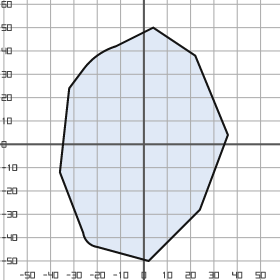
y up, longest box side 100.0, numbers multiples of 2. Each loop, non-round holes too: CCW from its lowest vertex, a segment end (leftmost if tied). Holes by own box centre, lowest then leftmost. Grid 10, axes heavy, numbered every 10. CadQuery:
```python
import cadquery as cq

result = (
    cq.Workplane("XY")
    .moveTo(2.0, -50.0)
    .lineTo(24.0, -28.0)
    .lineTo(36.0, 4.0)
    .lineTo(22.0, 38.0)
    .lineTo(4.0, 50.0)
    .lineTo(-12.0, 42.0)
    .threePointArc((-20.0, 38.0), (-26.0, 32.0))
    .lineTo(-32.0, 24.0)
    .lineTo(-36.0, -12.0)
    .lineTo(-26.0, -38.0)
    .threePointArc((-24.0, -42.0), (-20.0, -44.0))
    .close()
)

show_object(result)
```